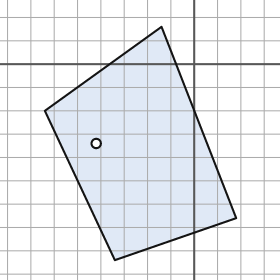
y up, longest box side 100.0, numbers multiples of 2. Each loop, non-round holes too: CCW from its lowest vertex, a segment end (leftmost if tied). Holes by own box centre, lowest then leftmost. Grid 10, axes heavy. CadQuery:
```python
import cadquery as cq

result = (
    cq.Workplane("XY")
    .moveTo(-34.0, -84.0)
    .lineTo(18.0, -66.0)
    .lineTo(-14.0, 16.0)
    .lineTo(-64.0, -20.0)
    .close()
    .moveTo(-42.0, -34.0)
    .circle(2.0)
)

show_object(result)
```